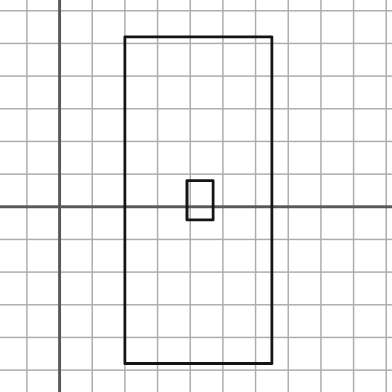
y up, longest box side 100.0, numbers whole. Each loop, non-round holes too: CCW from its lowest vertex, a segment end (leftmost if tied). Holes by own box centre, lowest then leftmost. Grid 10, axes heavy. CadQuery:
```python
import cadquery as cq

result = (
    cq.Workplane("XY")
    .moveTo(20.0, -48.0)
    .lineTo(65.0, -48.0)
    .lineTo(65.0, 52.0)
    .lineTo(20.0, 52.0)
    .close()
    .moveTo(39.0, -4.0)
    .lineTo(47.0, -4.0)
    .lineTo(47.0, 8.0)
    .lineTo(39.0, 8.0)
    .close()
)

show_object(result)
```